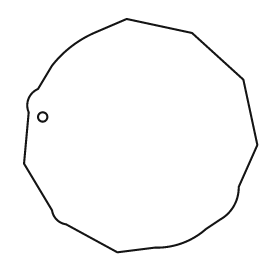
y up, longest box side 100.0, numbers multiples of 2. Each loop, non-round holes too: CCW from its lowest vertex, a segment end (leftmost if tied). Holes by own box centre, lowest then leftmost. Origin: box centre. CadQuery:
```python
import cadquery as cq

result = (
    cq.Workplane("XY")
    .moveTo(-10.0, -50.0)
    .lineTo(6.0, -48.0)
    .threePointArc((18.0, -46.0), (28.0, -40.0))
    .lineTo(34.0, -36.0)
    .threePointArc((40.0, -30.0), (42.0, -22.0))
    .lineTo(50.0, -4.0)
    .lineTo(44.0, 24.0)
    .lineTo(22.0, 44.0)
    .lineTo(-6.0, 50.0)
    .lineTo(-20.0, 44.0)
    .threePointArc((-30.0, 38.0), (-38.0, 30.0))
    .lineTo(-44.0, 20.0)
    .threePointArc((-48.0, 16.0), (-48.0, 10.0))
    .lineTo(-50.0, -12.0)
    .lineTo(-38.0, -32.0)
    .threePointArc((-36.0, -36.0), (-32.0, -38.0))
    .close()
    .moveTo(-42.0, 8.0)
    .circle(2.0)
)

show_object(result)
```